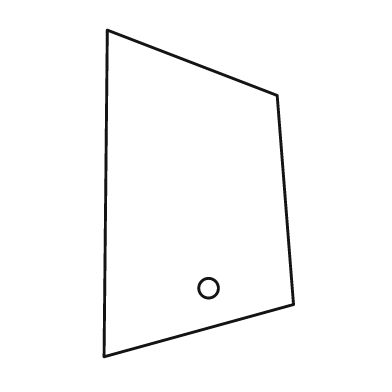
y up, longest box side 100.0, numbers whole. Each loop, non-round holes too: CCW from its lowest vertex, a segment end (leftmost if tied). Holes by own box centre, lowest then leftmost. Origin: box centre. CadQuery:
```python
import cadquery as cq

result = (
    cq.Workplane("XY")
    .moveTo(-29.0, -50.0)
    .lineTo(29.0, -34.0)
    .lineTo(24.0, 30.0)
    .lineTo(-28.0, 50.0)
    .close()
    .moveTo(3.0, -29.0)
    .circle(3.0)
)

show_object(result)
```